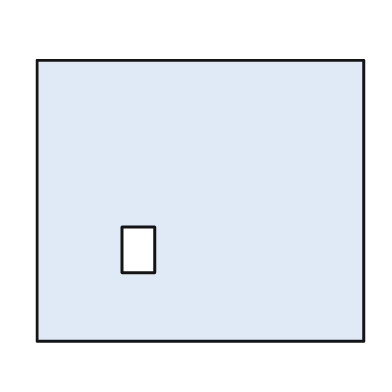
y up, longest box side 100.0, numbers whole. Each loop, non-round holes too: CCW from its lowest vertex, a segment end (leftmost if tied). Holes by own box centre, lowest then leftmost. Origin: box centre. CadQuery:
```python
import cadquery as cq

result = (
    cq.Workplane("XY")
    .moveTo(-50.0, -43.0)
    .lineTo(50.0, -43.0)
    .lineTo(50.0, 43.0)
    .lineTo(-50.0, 43.0)
    .close()
    .moveTo(-24.0, -22.0)
    .lineTo(-14.0, -22.0)
    .lineTo(-14.0, -8.0)
    .lineTo(-24.0, -8.0)
    .close()
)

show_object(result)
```